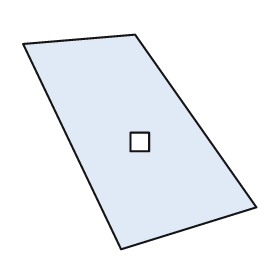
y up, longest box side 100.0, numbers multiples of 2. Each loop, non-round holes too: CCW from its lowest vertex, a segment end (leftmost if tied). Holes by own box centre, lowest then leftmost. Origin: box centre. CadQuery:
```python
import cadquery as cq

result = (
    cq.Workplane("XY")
    .moveTo(-8.0, -46.0)
    .lineTo(50.0, -28.0)
    .lineTo(-2.0, 46.0)
    .lineTo(-50.0, 42.0)
    .close()
    .moveTo(-4.0, -4.0)
    .lineTo(4.0, -4.0)
    .lineTo(4.0, 4.0)
    .lineTo(-4.0, 4.0)
    .close()
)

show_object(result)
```